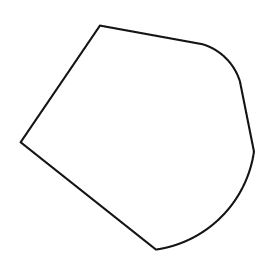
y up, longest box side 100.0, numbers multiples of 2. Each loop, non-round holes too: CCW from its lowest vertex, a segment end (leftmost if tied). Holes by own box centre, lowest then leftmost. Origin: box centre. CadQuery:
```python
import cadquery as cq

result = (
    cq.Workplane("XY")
    .moveTo(8.0, -48.0)
    .threePointArc((36.0, -34.0), (50.0, -6.0))
    .lineTo(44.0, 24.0)
    .threePointArc((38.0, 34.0), (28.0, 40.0))
    .lineTo(-16.0, 48.0)
    .lineTo(-50.0, -2.0)
    .close()
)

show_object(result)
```